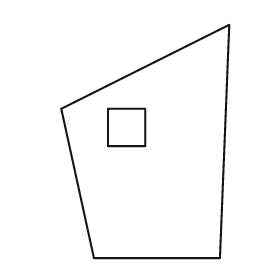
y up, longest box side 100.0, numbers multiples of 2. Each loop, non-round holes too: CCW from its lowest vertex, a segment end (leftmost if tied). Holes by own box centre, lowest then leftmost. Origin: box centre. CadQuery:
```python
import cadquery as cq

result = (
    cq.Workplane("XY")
    .moveTo(-22.0, -50.0)
    .lineTo(32.0, -50.0)
    .lineTo(36.0, 50.0)
    .lineTo(-36.0, 14.0)
    .close()
    .moveTo(-16.0, -2.0)
    .lineTo(0.0, -2.0)
    .lineTo(0.0, 14.0)
    .lineTo(-16.0, 14.0)
    .close()
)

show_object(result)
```